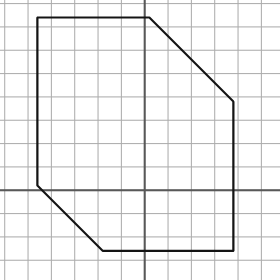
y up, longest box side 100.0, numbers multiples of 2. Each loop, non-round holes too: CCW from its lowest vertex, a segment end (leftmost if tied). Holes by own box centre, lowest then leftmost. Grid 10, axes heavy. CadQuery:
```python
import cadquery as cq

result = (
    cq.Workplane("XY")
    .moveTo(-18.0, -26.0)
    .lineTo(38.0, -26.0)
    .lineTo(38.0, 38.0)
    .lineTo(2.0, 74.0)
    .lineTo(-46.0, 74.0)
    .lineTo(-46.0, 2.0)
    .close()
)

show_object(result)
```